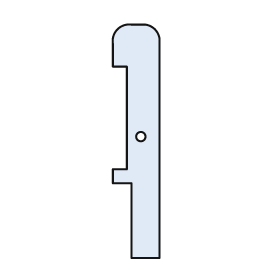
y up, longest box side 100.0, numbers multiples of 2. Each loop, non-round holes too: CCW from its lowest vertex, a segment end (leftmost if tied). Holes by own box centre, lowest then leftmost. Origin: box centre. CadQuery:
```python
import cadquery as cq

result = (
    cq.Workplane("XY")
    .moveTo(-2.0, -50.0)
    .lineTo(10.0, -50.0)
    .lineTo(10.0, 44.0)
    .threePointArc((8.0, 48.0), (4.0, 50.0))
    .lineTo(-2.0, 50.0)
    .threePointArc((-8.0, 48.0), (-10.0, 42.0))
    .lineTo(-10.0, 32.0)
    .lineTo(-4.0, 32.0)
    .lineTo(-4.0, -12.0)
    .lineTo(-10.0, -12.0)
    .lineTo(-10.0, -18.0)
    .lineTo(-2.0, -18.0)
    .close()
    .moveTo(2.0, 2.0)
    .circle(2.0)
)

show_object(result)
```